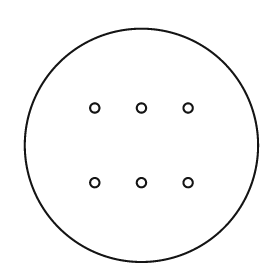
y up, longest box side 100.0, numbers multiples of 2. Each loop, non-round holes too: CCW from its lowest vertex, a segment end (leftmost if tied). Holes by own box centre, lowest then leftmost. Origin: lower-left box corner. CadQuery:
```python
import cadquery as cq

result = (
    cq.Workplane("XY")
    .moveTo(50.0, 50.0)
    .circle(50.0)
    .moveTo(30.0, 34.0)
    .circle(2.0)
    .moveTo(50.0, 34.0)
    .circle(2.0)
    .moveTo(70.0, 34.0)
    .circle(2.0)
    .moveTo(30.0, 66.0)
    .circle(2.0)
    .moveTo(50.0, 66.0)
    .circle(2.0)
    .moveTo(70.0, 66.0)
    .circle(2.0)
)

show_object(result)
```